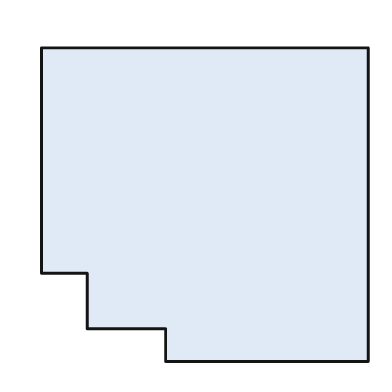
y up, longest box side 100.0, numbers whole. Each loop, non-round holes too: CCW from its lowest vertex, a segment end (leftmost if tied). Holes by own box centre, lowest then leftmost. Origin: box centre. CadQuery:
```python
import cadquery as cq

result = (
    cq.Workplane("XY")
    .moveTo(-12.0, -48.0)
    .lineTo(50.0, -48.0)
    .lineTo(50.0, 48.0)
    .lineTo(-50.0, 48.0)
    .lineTo(-50.0, -21.0)
    .lineTo(-36.0, -21.0)
    .lineTo(-36.0, -38.0)
    .lineTo(-12.0, -38.0)
    .close()
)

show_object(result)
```